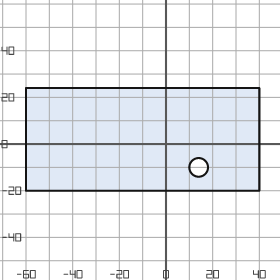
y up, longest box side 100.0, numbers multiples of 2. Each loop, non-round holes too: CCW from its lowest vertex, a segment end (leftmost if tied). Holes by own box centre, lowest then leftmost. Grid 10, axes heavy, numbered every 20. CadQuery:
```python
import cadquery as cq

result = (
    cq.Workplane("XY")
    .moveTo(-60.0, -20.0)
    .lineTo(40.0, -20.0)
    .lineTo(40.0, 24.0)
    .lineTo(-60.0, 24.0)
    .close()
    .moveTo(14.0, -10.0)
    .circle(4.0)
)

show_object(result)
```